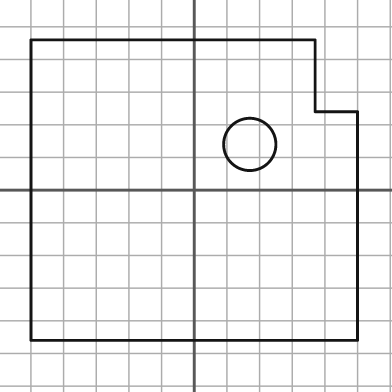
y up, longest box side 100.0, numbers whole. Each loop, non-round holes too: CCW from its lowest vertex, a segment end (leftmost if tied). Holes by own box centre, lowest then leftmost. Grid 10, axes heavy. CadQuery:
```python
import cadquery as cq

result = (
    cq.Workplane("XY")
    .moveTo(-50.0, -46.0)
    .lineTo(50.0, -46.0)
    .lineTo(50.0, 24.0)
    .lineTo(37.0, 24.0)
    .lineTo(37.0, 46.0)
    .lineTo(-50.0, 46.0)
    .close()
    .moveTo(17.0, 14.0)
    .circle(8.0)
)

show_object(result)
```